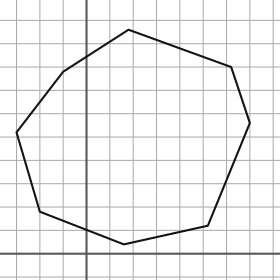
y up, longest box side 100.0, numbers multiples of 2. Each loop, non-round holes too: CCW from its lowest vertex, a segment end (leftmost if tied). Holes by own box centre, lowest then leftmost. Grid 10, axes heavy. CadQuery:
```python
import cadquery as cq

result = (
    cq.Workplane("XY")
    .moveTo(16.0, 4.0)
    .lineTo(52.0, 12.0)
    .lineTo(70.0, 56.0)
    .lineTo(62.0, 80.0)
    .lineTo(18.0, 96.0)
    .lineTo(-10.0, 78.0)
    .lineTo(-30.0, 52.0)
    .lineTo(-20.0, 18.0)
    .close()
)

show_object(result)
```